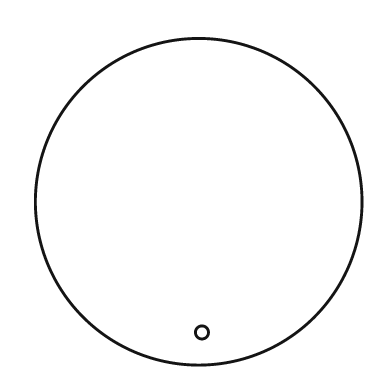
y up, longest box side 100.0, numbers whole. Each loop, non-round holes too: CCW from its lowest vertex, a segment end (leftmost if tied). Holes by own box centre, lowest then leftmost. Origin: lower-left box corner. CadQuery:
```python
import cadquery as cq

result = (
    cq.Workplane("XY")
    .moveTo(50.0, 50.0)
    .circle(50.0)
    .moveTo(51.0, 10.0)
    .circle(2.0)
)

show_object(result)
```